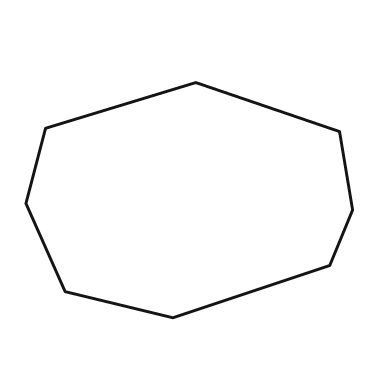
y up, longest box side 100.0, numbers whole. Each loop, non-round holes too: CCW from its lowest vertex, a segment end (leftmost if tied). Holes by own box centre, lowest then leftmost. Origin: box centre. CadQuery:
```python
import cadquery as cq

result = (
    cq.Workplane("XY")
    .moveTo(-5.0, -36.0)
    .lineTo(43.0, -20.0)
    .lineTo(50.0, -3.0)
    .lineTo(46.0, 21.0)
    .lineTo(2.0, 36.0)
    .lineTo(-44.0, 22.0)
    .lineTo(-50.0, -1.0)
    .lineTo(-38.0, -28.0)
    .close()
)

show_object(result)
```